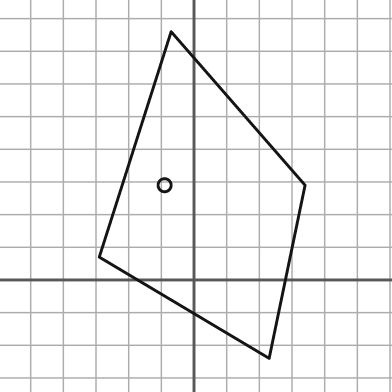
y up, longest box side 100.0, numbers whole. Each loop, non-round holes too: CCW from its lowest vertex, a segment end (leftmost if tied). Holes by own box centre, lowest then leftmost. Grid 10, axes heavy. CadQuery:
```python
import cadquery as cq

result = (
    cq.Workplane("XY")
    .moveTo(23.0, -24.0)
    .lineTo(34.0, 29.0)
    .lineTo(-7.0, 76.0)
    .lineTo(-29.0, 7.0)
    .close()
    .moveTo(-9.0, 29.0)
    .circle(2.0)
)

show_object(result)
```